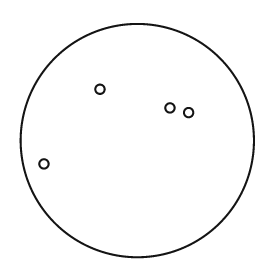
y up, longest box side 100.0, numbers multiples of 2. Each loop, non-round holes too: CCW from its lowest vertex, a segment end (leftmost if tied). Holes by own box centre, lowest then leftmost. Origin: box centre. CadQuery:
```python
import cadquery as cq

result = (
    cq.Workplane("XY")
    .moveTo(0.0, 0.0)
    .circle(50.0)
    .moveTo(-40.0, -10.0)
    .circle(2.0)
    .moveTo(22.0, 12.0)
    .circle(2.0)
    .moveTo(14.0, 14.0)
    .circle(2.0)
    .moveTo(-16.0, 22.0)
    .circle(2.0)
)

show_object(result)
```